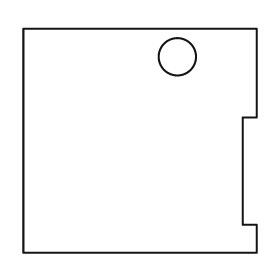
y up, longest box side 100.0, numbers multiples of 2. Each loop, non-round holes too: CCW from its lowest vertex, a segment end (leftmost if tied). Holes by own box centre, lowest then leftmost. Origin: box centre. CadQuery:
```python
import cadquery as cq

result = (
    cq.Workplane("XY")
    .moveTo(-50.0, -48.0)
    .lineTo(50.0, -48.0)
    .lineTo(50.0, -36.0)
    .lineTo(44.0, -36.0)
    .lineTo(44.0, 10.0)
    .lineTo(50.0, 10.0)
    .lineTo(50.0, 48.0)
    .lineTo(-50.0, 48.0)
    .close()
    .moveTo(16.0, 36.0)
    .circle(8.0)
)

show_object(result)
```